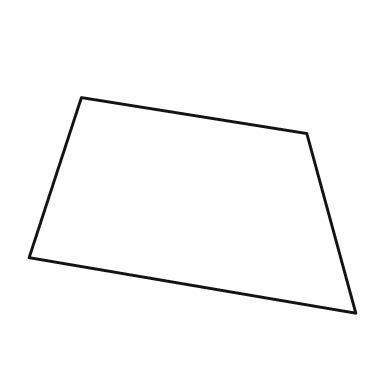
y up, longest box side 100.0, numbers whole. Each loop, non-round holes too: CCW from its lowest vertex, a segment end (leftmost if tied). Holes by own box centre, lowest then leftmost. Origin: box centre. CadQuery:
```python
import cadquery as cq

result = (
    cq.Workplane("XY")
    .moveTo(50.0, -33.0)
    .lineTo(35.0, 22.0)
    .lineTo(-34.0, 33.0)
    .lineTo(-50.0, -16.0)
    .close()
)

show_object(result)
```